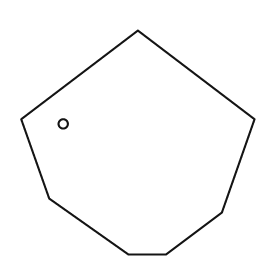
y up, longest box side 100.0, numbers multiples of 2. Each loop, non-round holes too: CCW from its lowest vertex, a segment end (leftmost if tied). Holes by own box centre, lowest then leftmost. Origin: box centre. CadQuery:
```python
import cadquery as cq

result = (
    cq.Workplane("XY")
    .moveTo(-4.0, -48.0)
    .lineTo(12.0, -48.0)
    .lineTo(36.0, -30.0)
    .lineTo(50.0, 10.0)
    .lineTo(0.0, 48.0)
    .lineTo(-50.0, 10.0)
    .lineTo(-38.0, -24.0)
    .close()
    .moveTo(-32.0, 8.0)
    .circle(2.0)
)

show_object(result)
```